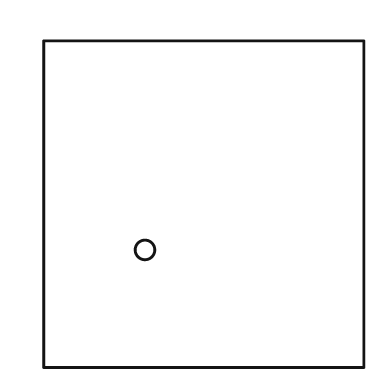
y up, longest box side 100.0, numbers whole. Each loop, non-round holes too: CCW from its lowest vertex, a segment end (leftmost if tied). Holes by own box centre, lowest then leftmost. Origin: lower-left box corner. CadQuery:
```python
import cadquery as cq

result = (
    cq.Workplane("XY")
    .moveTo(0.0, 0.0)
    .lineTo(98.0, 0.0)
    .lineTo(98.0, 100.0)
    .lineTo(0.0, 100.0)
    .close()
    .moveTo(31.0, 36.0)
    .circle(3.0)
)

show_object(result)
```